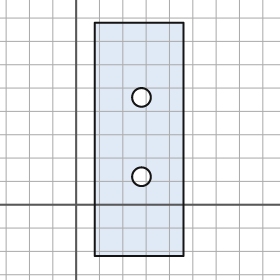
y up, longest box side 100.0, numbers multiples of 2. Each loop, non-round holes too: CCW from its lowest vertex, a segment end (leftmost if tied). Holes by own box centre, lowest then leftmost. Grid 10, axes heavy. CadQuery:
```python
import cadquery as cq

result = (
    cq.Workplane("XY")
    .moveTo(8.0, -22.0)
    .lineTo(46.0, -22.0)
    .lineTo(46.0, 78.0)
    .lineTo(8.0, 78.0)
    .close()
    .moveTo(28.0, 12.0)
    .circle(4.0)
    .moveTo(28.0, 46.0)
    .circle(4.0)
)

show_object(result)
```